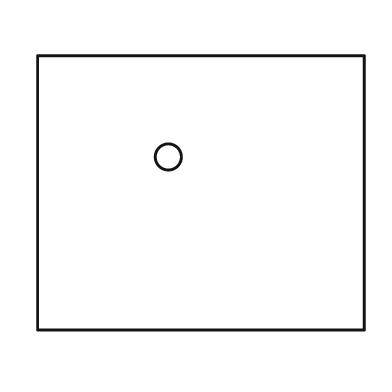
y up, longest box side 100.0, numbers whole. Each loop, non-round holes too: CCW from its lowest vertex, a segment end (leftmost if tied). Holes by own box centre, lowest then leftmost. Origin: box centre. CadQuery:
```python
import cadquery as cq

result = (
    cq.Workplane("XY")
    .moveTo(-50.0, -42.0)
    .lineTo(50.0, -42.0)
    .lineTo(50.0, 42.0)
    .lineTo(-50.0, 42.0)
    .close()
    .moveTo(-10.0, 11.0)
    .circle(4.0)
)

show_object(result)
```